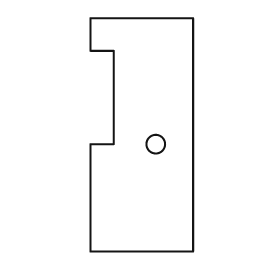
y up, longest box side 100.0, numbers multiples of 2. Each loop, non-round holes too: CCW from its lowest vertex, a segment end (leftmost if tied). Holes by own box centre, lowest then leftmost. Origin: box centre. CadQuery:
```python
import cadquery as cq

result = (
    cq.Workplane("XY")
    .moveTo(-22.0, -50.0)
    .lineTo(22.0, -50.0)
    .lineTo(22.0, 50.0)
    .lineTo(-22.0, 50.0)
    .lineTo(-22.0, 36.0)
    .lineTo(-12.0, 36.0)
    .lineTo(-12.0, -4.0)
    .lineTo(-22.0, -4.0)
    .close()
    .moveTo(6.0, -4.0)
    .circle(4.0)
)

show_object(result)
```